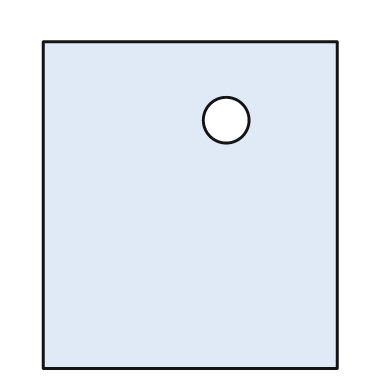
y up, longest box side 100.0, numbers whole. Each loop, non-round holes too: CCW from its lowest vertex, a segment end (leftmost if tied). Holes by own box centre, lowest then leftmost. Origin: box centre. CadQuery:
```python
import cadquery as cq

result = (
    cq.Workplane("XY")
    .moveTo(-45.0, -50.0)
    .lineTo(45.0, -50.0)
    .lineTo(45.0, 50.0)
    .lineTo(-45.0, 50.0)
    .close()
    .moveTo(11.0, 26.0)
    .circle(7.0)
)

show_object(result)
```